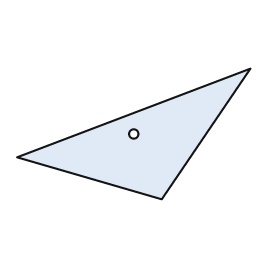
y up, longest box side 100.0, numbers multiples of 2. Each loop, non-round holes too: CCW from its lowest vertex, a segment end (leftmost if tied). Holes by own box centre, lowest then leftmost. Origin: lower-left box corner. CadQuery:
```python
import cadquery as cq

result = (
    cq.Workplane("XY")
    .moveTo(62.0, 0.0)
    .lineTo(100.0, 56.0)
    .lineTo(0.0, 18.0)
    .close()
    .moveTo(50.0, 28.0)
    .circle(2.0)
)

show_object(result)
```